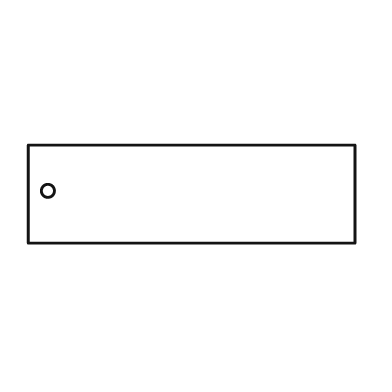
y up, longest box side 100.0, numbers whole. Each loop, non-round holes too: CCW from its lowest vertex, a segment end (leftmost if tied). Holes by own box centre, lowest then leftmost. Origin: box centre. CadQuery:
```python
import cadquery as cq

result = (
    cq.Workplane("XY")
    .moveTo(-50.0, -15.0)
    .lineTo(50.0, -15.0)
    .lineTo(50.0, 15.0)
    .lineTo(-50.0, 15.0)
    .close()
    .moveTo(-44.0, 1.0)
    .circle(2.0)
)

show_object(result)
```